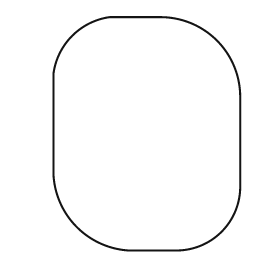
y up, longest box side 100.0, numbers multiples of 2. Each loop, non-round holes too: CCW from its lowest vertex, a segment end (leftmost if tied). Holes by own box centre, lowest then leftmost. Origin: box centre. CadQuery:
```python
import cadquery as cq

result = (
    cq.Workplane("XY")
    .moveTo(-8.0, -50.0)
    .lineTo(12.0, -50.0)
    .threePointArc((32.0, -42.0), (40.0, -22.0))
    .lineTo(40.0, 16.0)
    .threePointArc((30.0, 40.0), (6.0, 50.0))
    .lineTo(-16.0, 50.0)
    .threePointArc((-32.0, 42.0), (-40.0, 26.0))
    .lineTo(-40.0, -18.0)
    .threePointArc((-30.0, -40.0), (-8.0, -50.0))
    .close()
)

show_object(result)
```